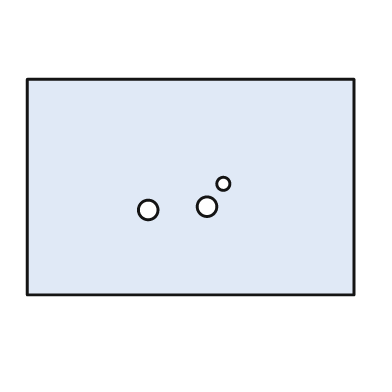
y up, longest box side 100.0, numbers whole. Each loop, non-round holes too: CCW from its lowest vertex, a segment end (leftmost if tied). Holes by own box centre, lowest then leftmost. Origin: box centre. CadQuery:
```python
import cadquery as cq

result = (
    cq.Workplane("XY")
    .moveTo(-50.0, -33.0)
    .lineTo(50.0, -33.0)
    .lineTo(50.0, 33.0)
    .lineTo(-50.0, 33.0)
    .close()
    .moveTo(-13.0, -7.0)
    .circle(3.0)
    .moveTo(5.0, -6.0)
    .circle(3.0)
    .moveTo(10.0, 1.0)
    .circle(2.0)
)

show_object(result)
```